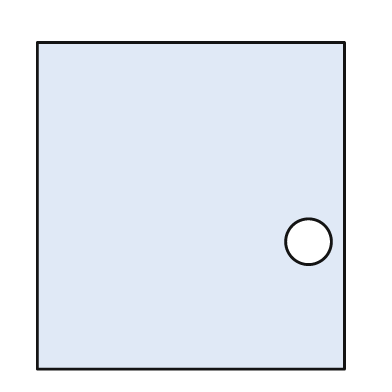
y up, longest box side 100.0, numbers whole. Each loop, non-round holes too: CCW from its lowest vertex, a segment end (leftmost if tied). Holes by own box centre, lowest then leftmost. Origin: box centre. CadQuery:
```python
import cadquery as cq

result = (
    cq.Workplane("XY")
    .moveTo(-47.0, -50.0)
    .lineTo(47.0, -50.0)
    .lineTo(47.0, 50.0)
    .lineTo(-47.0, 50.0)
    .close()
    .moveTo(36.0, -11.0)
    .circle(7.0)
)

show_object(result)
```